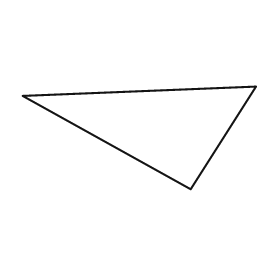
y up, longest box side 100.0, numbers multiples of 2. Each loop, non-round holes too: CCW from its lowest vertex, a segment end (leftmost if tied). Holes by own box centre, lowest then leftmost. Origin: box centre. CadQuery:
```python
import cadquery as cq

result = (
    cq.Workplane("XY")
    .moveTo(22.0, -22.0)
    .lineTo(50.0, 22.0)
    .lineTo(-50.0, 18.0)
    .close()
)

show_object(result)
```